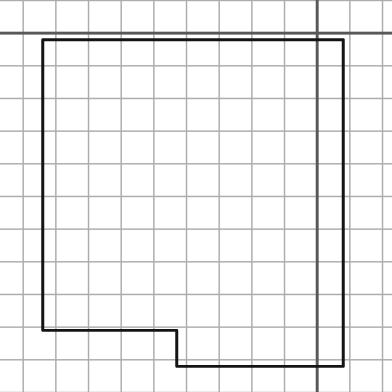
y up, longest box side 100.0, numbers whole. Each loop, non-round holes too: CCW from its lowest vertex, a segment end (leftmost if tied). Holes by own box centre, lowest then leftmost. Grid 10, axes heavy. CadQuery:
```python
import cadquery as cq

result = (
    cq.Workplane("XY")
    .moveTo(-43.0, -102.0)
    .lineTo(8.0, -102.0)
    .lineTo(8.0, -2.0)
    .lineTo(-84.0, -2.0)
    .lineTo(-84.0, -91.0)
    .lineTo(-43.0, -91.0)
    .close()
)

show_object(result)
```